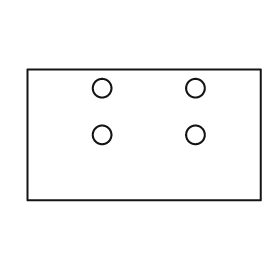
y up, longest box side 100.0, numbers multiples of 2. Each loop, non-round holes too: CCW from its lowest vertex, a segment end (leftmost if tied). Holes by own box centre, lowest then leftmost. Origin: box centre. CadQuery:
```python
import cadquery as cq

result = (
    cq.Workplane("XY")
    .moveTo(-50.0, -28.0)
    .lineTo(50.0, -28.0)
    .lineTo(50.0, 28.0)
    .lineTo(-50.0, 28.0)
    .close()
    .moveTo(-18.0, 0.0)
    .circle(4.0)
    .moveTo(22.0, 0.0)
    .circle(4.0)
    .moveTo(-18.0, 20.0)
    .circle(4.0)
    .moveTo(22.0, 20.0)
    .circle(4.0)
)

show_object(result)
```